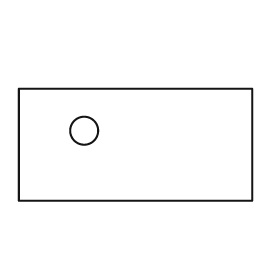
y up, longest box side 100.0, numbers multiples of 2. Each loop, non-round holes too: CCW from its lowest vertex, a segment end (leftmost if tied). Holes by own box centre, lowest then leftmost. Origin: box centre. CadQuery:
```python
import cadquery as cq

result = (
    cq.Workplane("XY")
    .moveTo(-50.0, -24.0)
    .lineTo(50.0, -24.0)
    .lineTo(50.0, 24.0)
    .lineTo(-50.0, 24.0)
    .close()
    .moveTo(-22.0, 6.0)
    .circle(6.0)
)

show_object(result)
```